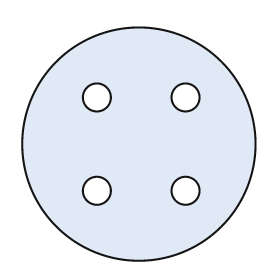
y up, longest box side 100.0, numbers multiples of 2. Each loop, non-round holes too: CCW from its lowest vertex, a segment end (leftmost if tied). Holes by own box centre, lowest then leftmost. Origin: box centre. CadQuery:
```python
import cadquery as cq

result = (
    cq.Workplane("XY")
    .moveTo(0.0, 0.0)
    .circle(50.0)
    .moveTo(-18.0, -20.0)
    .circle(6.0)
    .moveTo(20.0, -20.0)
    .circle(6.0)
    .moveTo(-18.0, 20.0)
    .circle(6.0)
    .moveTo(20.0, 20.0)
    .circle(6.0)
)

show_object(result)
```